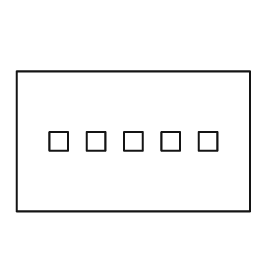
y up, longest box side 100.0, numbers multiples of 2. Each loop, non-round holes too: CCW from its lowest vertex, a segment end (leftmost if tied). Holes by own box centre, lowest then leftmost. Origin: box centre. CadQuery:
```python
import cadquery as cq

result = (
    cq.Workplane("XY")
    .moveTo(-50.0, -30.0)
    .lineTo(50.0, -30.0)
    .lineTo(50.0, 30.0)
    .lineTo(-50.0, 30.0)
    .close()
    .moveTo(-36.0, -4.0)
    .lineTo(-28.0, -4.0)
    .lineTo(-28.0, 4.0)
    .lineTo(-36.0, 4.0)
    .close()
    .moveTo(-20.0, -4.0)
    .lineTo(-12.0, -4.0)
    .lineTo(-12.0, 4.0)
    .lineTo(-20.0, 4.0)
    .close()
    .moveTo(-4.0, -4.0)
    .lineTo(4.0, -4.0)
    .lineTo(4.0, 4.0)
    .lineTo(-4.0, 4.0)
    .close()
    .moveTo(12.0, -4.0)
    .lineTo(20.0, -4.0)
    .lineTo(20.0, 4.0)
    .lineTo(12.0, 4.0)
    .close()
    .moveTo(28.0, -4.0)
    .lineTo(36.0, -4.0)
    .lineTo(36.0, 4.0)
    .lineTo(28.0, 4.0)
    .close()
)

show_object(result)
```